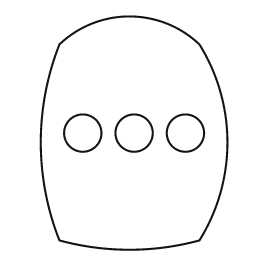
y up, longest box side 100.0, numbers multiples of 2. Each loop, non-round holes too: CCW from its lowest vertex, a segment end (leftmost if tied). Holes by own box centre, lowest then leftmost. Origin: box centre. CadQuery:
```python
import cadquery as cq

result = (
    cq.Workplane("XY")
    .moveTo(-32.0, -46.0)
    .threePointArc((-2.0, -50.0), (28.0, -46.0))
    .threePointArc((40.0, -4.0), (28.0, 38.0))
    .threePointArc((-2.0, 50.0), (-32.0, 38.0))
    .threePointArc((-40.0, -4.0), (-32.0, -46.0))
    .close()
    .moveTo(-22.0, 0.0)
    .circle(8.0)
    .moveTo(0.0, 0.0)
    .circle(8.0)
    .moveTo(22.0, 0.0)
    .circle(8.0)
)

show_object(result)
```